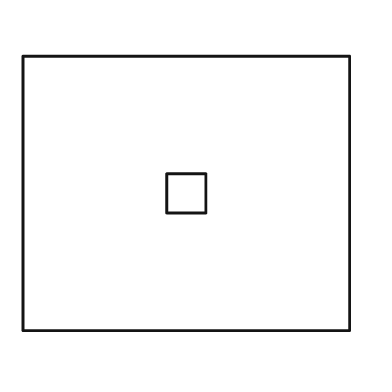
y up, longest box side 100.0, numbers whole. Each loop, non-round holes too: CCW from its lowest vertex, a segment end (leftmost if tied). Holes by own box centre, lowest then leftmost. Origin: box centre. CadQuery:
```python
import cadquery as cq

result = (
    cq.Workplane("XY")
    .moveTo(-50.0, -42.0)
    .lineTo(50.0, -42.0)
    .lineTo(50.0, 42.0)
    .lineTo(-50.0, 42.0)
    .close()
    .moveTo(-6.0, -6.0)
    .lineTo(6.0, -6.0)
    .lineTo(6.0, 6.0)
    .lineTo(-6.0, 6.0)
    .close()
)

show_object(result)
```